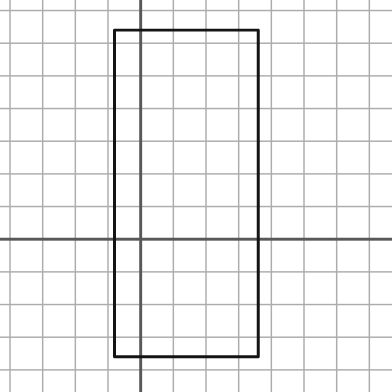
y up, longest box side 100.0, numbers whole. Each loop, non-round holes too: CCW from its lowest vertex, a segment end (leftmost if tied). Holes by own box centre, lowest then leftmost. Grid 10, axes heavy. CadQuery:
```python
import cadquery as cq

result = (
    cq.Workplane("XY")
    .moveTo(-8.0, -36.0)
    .lineTo(36.0, -36.0)
    .lineTo(36.0, 64.0)
    .lineTo(-8.0, 64.0)
    .close()
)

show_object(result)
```